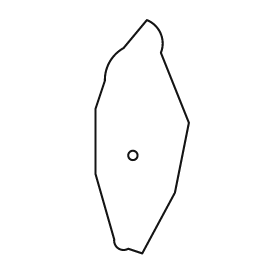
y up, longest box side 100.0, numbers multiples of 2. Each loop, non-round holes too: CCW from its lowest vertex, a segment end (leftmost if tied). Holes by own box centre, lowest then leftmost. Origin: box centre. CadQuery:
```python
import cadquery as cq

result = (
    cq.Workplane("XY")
    .moveTo(0.0, -50.0)
    .lineTo(14.0, -24.0)
    .lineTo(20.0, 6.0)
    .lineTo(8.0, 36.0)
    .threePointArc((8.0, 44.0), (2.0, 50.0))
    .lineTo(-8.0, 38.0)
    .threePointArc((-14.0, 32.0), (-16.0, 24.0))
    .lineTo(-20.0, 12.0)
    .lineTo(-20.0, -16.0)
    .lineTo(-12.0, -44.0)
    .threePointArc((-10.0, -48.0), (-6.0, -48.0))
    .close()
    .moveTo(-4.0, -8.0)
    .circle(2.0)
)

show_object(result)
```